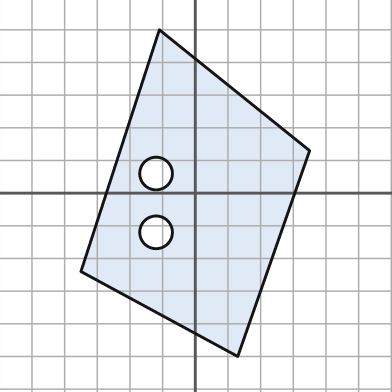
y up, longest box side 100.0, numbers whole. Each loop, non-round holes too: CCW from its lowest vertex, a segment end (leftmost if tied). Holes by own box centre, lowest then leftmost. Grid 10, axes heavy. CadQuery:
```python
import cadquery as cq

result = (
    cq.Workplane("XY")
    .moveTo(13.0, -50.0)
    .lineTo(35.0, 13.0)
    .lineTo(-11.0, 50.0)
    .lineTo(-35.0, -24.0)
    .close()
    .moveTo(-12.0, -12.0)
    .circle(5.0)
    .moveTo(-12.0, 6.0)
    .circle(5.0)
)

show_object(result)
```